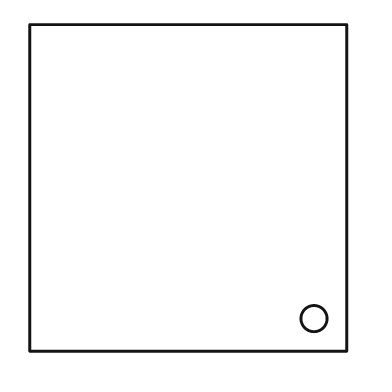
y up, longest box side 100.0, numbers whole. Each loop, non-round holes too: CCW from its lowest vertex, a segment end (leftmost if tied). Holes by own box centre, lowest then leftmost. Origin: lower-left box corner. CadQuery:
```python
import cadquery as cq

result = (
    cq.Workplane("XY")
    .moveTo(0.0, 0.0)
    .lineTo(97.0, 0.0)
    .lineTo(97.0, 100.0)
    .lineTo(0.0, 100.0)
    .close()
    .moveTo(87.0, 10.0)
    .circle(4.0)
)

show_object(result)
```